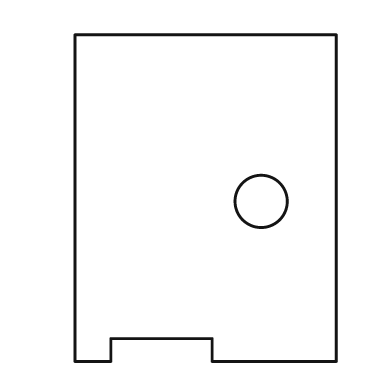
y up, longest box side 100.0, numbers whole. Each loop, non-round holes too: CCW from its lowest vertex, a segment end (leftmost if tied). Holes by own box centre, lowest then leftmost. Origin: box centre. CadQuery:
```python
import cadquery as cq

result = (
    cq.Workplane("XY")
    .moveTo(-40.0, -50.0)
    .lineTo(-29.0, -50.0)
    .lineTo(-29.0, -43.0)
    .lineTo(2.0, -43.0)
    .lineTo(2.0, -50.0)
    .lineTo(40.0, -50.0)
    .lineTo(40.0, 50.0)
    .lineTo(-40.0, 50.0)
    .close()
    .moveTo(17.0, -1.0)
    .circle(8.0)
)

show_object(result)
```